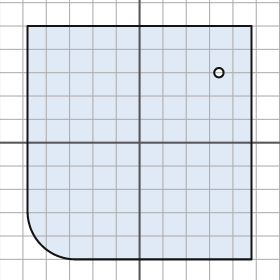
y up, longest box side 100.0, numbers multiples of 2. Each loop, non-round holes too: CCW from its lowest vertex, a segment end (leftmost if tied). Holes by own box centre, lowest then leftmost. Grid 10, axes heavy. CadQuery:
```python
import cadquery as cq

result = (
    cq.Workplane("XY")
    .moveTo(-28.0, -50.0)
    .lineTo(48.0, -50.0)
    .lineTo(48.0, 50.0)
    .lineTo(-48.0, 50.0)
    .lineTo(-48.0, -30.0)
    .threePointArc((-42.0, -44.0), (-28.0, -50.0))
    .close()
    .moveTo(34.0, 30.0)
    .circle(2.0)
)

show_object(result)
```